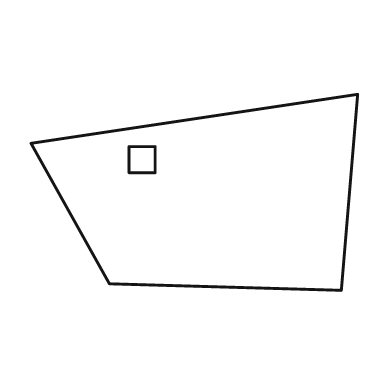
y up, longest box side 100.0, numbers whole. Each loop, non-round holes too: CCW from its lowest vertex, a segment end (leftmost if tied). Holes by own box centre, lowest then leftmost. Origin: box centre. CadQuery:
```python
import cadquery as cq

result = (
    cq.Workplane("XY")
    .moveTo(45.0, -30.0)
    .lineTo(50.0, 30.0)
    .lineTo(-50.0, 15.0)
    .lineTo(-26.0, -28.0)
    .close()
    .moveTo(-20.0, 6.0)
    .lineTo(-12.0, 6.0)
    .lineTo(-12.0, 14.0)
    .lineTo(-20.0, 14.0)
    .close()
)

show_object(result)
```